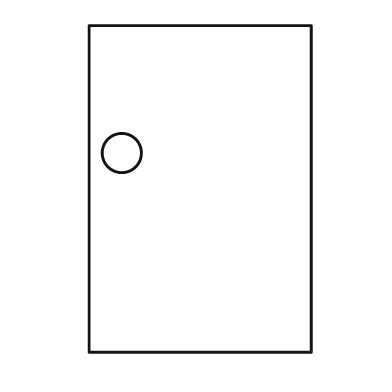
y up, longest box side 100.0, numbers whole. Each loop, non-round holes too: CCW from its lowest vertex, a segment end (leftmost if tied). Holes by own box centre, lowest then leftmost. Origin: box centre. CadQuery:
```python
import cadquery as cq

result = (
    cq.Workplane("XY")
    .moveTo(-34.0, -50.0)
    .lineTo(34.0, -50.0)
    .lineTo(34.0, 50.0)
    .lineTo(-34.0, 50.0)
    .close()
    .moveTo(-24.0, 11.0)
    .circle(6.0)
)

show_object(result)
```